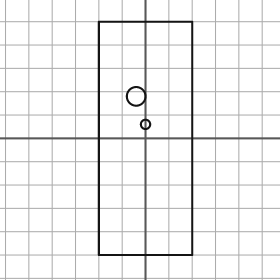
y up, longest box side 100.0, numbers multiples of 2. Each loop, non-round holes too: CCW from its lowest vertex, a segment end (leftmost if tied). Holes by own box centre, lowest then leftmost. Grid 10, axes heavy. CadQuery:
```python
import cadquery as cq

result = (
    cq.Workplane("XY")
    .moveTo(-20.0, -50.0)
    .lineTo(20.0, -50.0)
    .lineTo(20.0, 50.0)
    .lineTo(-20.0, 50.0)
    .close()
    .moveTo(0.0, 6.0)
    .circle(2.0)
    .moveTo(-4.0, 18.0)
    .circle(4.0)
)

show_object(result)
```